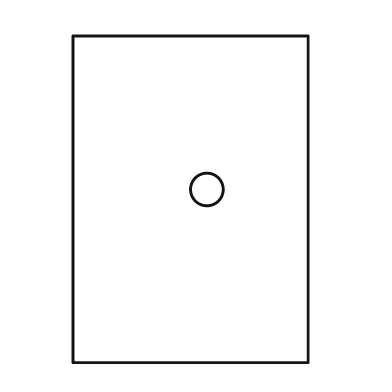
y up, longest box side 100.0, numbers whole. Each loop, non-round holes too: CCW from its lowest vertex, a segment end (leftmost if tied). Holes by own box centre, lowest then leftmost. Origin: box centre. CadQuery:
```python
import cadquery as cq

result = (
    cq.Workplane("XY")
    .moveTo(-36.0, -50.0)
    .lineTo(36.0, -50.0)
    .lineTo(36.0, 50.0)
    .lineTo(-36.0, 50.0)
    .close()
    .moveTo(5.0, 3.0)
    .circle(5.0)
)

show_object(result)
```